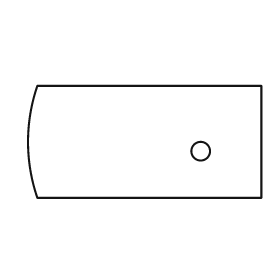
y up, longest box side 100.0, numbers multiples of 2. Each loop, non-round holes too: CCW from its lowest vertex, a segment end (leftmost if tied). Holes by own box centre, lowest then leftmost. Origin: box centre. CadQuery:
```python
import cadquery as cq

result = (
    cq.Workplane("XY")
    .moveTo(-46.0, -24.0)
    .lineTo(50.0, -24.0)
    .lineTo(50.0, 24.0)
    .lineTo(-46.0, 24.0)
    .threePointArc((-50.0, 0.0), (-46.0, -24.0))
    .close()
    .moveTo(24.0, -4.0)
    .circle(4.0)
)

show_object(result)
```